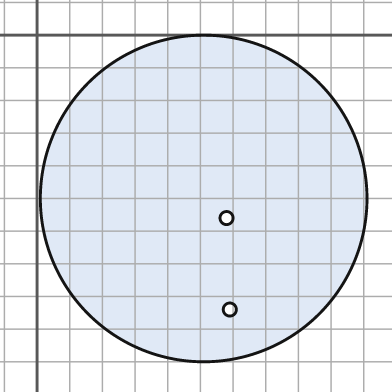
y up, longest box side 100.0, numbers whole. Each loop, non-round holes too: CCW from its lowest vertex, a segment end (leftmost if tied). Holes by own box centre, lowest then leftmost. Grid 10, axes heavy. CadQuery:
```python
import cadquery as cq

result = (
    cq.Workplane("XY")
    .moveTo(51.0, -50.0)
    .circle(50.0)
    .moveTo(59.0, -84.0)
    .circle(2.0)
    .moveTo(58.0, -56.0)
    .circle(2.0)
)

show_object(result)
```